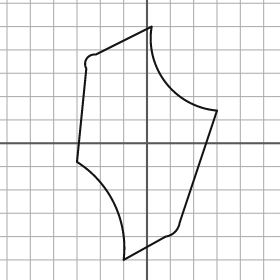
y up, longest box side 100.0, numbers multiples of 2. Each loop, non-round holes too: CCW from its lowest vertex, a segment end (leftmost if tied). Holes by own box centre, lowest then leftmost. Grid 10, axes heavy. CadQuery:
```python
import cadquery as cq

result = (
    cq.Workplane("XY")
    .moveTo(-10.0, -50.0)
    .lineTo(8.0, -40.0)
    .threePointArc((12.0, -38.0), (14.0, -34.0))
    .lineTo(30.0, 14.0)
    .threePointArc((8.0, 26.0), (2.0, 50.0))
    .lineTo(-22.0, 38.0)
    .threePointArc((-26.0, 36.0), (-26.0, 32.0))
    .lineTo(-30.0, -8.0)
    .threePointArc((-14.0, -26.0), (-10.0, -50.0))
    .close()
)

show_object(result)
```